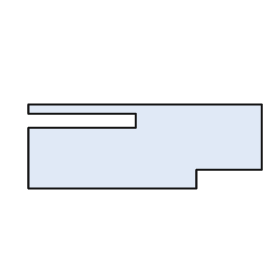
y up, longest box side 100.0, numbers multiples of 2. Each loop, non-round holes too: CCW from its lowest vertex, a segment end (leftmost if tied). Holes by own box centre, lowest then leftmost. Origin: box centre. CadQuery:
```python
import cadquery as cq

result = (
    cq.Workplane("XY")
    .moveTo(-50.0, -18.0)
    .lineTo(22.0, -18.0)
    .lineTo(22.0, -10.0)
    .lineTo(50.0, -10.0)
    .lineTo(50.0, 18.0)
    .lineTo(-50.0, 18.0)
    .lineTo(-50.0, 14.0)
    .lineTo(-4.0, 14.0)
    .lineTo(-4.0, 8.0)
    .lineTo(-50.0, 8.0)
    .close()
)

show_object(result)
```